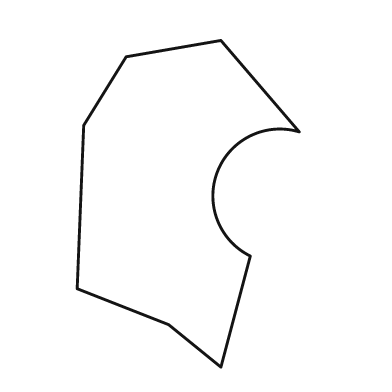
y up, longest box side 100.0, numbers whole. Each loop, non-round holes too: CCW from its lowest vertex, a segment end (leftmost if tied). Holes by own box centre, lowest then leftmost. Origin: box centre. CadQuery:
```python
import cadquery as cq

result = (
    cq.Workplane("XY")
    .moveTo(10.0, -50.0)
    .lineTo(19.0, -16.0)
    .threePointArc((9.0, 10.0), (34.0, 22.0))
    .lineTo(10.0, 50.0)
    .lineTo(-19.0, 45.0)
    .lineTo(-32.0, 24.0)
    .lineTo(-34.0, -26.0)
    .lineTo(-6.0, -37.0)
    .close()
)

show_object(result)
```